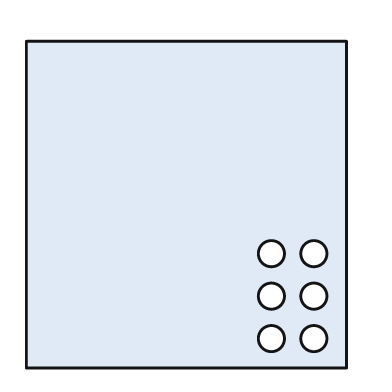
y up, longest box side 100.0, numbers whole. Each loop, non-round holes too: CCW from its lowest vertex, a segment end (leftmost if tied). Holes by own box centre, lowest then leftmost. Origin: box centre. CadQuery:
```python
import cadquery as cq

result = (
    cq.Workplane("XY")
    .moveTo(-49.0, -50.0)
    .lineTo(49.0, -50.0)
    .lineTo(49.0, 50.0)
    .lineTo(-49.0, 50.0)
    .close()
    .moveTo(26.0, -41.0)
    .circle(4.0)
    .moveTo(39.0, -41.0)
    .circle(4.0)
    .moveTo(26.0, -28.0)
    .circle(4.0)
    .moveTo(39.0, -28.0)
    .circle(4.0)
    .moveTo(26.0, -15.0)
    .circle(4.0)
    .moveTo(39.0, -15.0)
    .circle(4.0)
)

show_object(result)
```